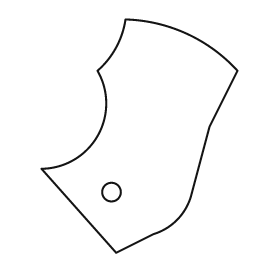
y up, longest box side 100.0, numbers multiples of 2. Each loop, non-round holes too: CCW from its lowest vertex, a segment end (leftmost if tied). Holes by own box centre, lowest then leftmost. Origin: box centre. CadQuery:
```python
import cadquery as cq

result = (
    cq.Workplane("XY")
    .moveTo(-10.0, -50.0)
    .lineTo(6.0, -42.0)
    .threePointArc((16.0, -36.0), (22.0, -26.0))
    .lineTo(30.0, 4.0)
    .lineTo(42.0, 28.0)
    .threePointArc((20.0, 44.0), (-6.0, 50.0))
    .threePointArc((-10.0, 38.0), (-18.0, 28.0))
    .threePointArc((-18.0, 0.0), (-42.0, -14.0))
    .close()
    .moveTo(-12.0, -24.0)
    .circle(4.0)
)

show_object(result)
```